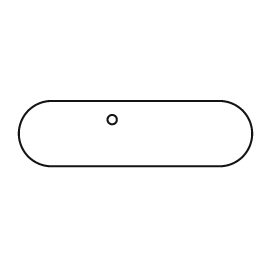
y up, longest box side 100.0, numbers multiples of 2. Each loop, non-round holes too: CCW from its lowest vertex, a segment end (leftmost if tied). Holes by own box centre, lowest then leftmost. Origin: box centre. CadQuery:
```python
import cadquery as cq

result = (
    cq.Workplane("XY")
    .moveTo(-36.0, -14.0)
    .lineTo(36.0, -14.0)
    .threePointArc((50.0, 0.0), (36.0, 14.0))
    .lineTo(-36.0, 14.0)
    .threePointArc((-50.0, 0.0), (-36.0, -14.0))
    .close()
    .moveTo(-10.0, 6.0)
    .circle(2.0)
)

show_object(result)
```